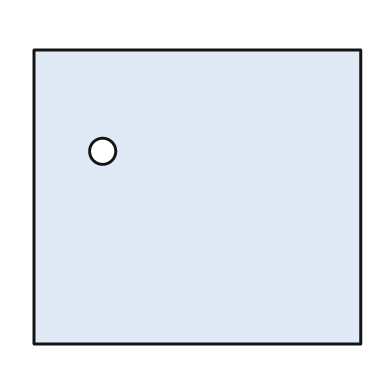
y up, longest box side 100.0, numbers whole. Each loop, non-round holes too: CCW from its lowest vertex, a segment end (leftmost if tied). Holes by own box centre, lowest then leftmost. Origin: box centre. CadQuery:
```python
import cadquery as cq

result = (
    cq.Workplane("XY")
    .moveTo(-50.0, -45.0)
    .lineTo(50.0, -45.0)
    .lineTo(50.0, 45.0)
    .lineTo(-50.0, 45.0)
    .close()
    .moveTo(-29.0, 14.0)
    .circle(4.0)
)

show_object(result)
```